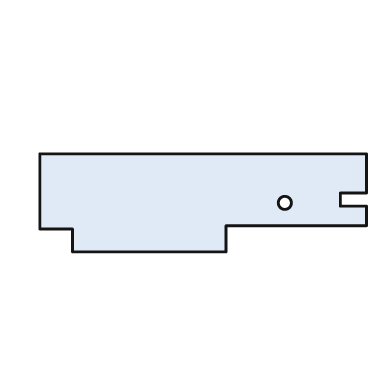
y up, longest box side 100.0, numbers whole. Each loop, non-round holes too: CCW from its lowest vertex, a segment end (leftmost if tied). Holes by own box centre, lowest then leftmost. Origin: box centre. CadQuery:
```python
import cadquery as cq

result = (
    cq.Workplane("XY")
    .moveTo(-40.0, -15.0)
    .lineTo(7.0, -15.0)
    .lineTo(7.0, -7.0)
    .lineTo(50.0, -7.0)
    .lineTo(50.0, -1.0)
    .lineTo(42.0, -1.0)
    .lineTo(42.0, 3.0)
    .lineTo(50.0, 3.0)
    .lineTo(50.0, 15.0)
    .lineTo(-50.0, 15.0)
    .lineTo(-50.0, -8.0)
    .lineTo(-40.0, -8.0)
    .close()
    .moveTo(25.0, 0.0)
    .circle(2.0)
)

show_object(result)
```